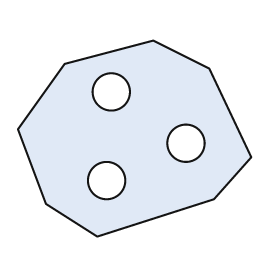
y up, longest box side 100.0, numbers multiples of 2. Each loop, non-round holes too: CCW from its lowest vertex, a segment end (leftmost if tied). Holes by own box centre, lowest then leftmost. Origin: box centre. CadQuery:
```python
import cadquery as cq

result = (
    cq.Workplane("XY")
    .moveTo(-16.0, -42.0)
    .lineTo(34.0, -26.0)
    .lineTo(50.0, -8.0)
    .lineTo(32.0, 30.0)
    .lineTo(8.0, 42.0)
    .lineTo(-30.0, 32.0)
    .lineTo(-50.0, 4.0)
    .lineTo(-38.0, -28.0)
    .close()
    .moveTo(-12.0, -18.0)
    .circle(8.0)
    .moveTo(22.0, -2.0)
    .circle(8.0)
    .moveTo(-10.0, 20.0)
    .circle(8.0)
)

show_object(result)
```